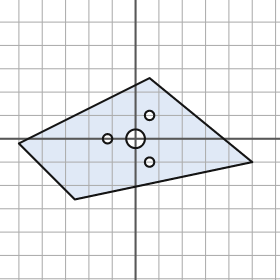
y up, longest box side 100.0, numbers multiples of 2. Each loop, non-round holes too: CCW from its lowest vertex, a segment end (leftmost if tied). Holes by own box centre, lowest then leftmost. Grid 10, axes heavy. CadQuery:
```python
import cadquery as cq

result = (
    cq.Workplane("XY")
    .moveTo(-26.0, -26.0)
    .lineTo(50.0, -10.0)
    .lineTo(6.0, 26.0)
    .lineTo(-50.0, -2.0)
    .close()
    .moveTo(6.0, -10.0)
    .circle(2.0)
    .moveTo(-12.0, 0.0)
    .circle(2.0)
    .moveTo(0.0, 0.0)
    .circle(4.0)
    .moveTo(6.0, 10.0)
    .circle(2.0)
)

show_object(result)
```